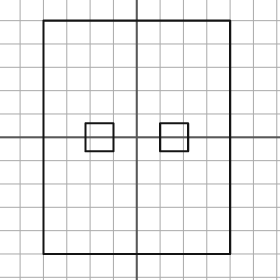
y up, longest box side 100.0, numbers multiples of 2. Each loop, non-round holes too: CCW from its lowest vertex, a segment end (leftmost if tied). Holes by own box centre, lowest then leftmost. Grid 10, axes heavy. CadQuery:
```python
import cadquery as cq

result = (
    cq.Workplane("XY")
    .moveTo(-40.0, -50.0)
    .lineTo(40.0, -50.0)
    .lineTo(40.0, 50.0)
    .lineTo(-40.0, 50.0)
    .close()
    .moveTo(-22.0, -6.0)
    .lineTo(-10.0, -6.0)
    .lineTo(-10.0, 6.0)
    .lineTo(-22.0, 6.0)
    .close()
    .moveTo(10.0, -6.0)
    .lineTo(22.0, -6.0)
    .lineTo(22.0, 6.0)
    .lineTo(10.0, 6.0)
    .close()
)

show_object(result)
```